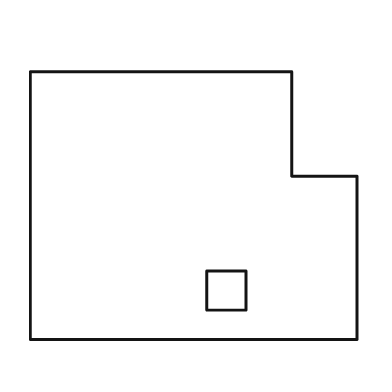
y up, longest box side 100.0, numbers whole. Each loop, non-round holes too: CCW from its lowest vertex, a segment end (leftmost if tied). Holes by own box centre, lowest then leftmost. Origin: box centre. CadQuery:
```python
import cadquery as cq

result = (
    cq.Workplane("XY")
    .moveTo(-50.0, -41.0)
    .lineTo(50.0, -41.0)
    .lineTo(50.0, 9.0)
    .lineTo(30.0, 9.0)
    .lineTo(30.0, 41.0)
    .lineTo(-50.0, 41.0)
    .close()
    .moveTo(4.0, -32.0)
    .lineTo(16.0, -32.0)
    .lineTo(16.0, -20.0)
    .lineTo(4.0, -20.0)
    .close()
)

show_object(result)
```